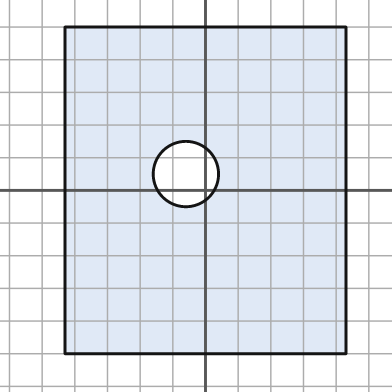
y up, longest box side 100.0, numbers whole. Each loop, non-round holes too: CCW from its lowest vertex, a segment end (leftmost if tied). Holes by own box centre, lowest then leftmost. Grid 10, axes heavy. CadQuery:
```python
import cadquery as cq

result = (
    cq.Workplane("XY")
    .moveTo(-43.0, -50.0)
    .lineTo(43.0, -50.0)
    .lineTo(43.0, 50.0)
    .lineTo(-43.0, 50.0)
    .close()
    .moveTo(-6.0, 5.0)
    .circle(10.0)
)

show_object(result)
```